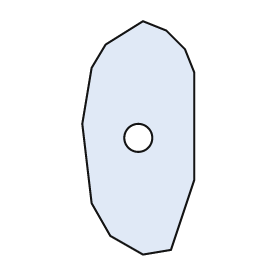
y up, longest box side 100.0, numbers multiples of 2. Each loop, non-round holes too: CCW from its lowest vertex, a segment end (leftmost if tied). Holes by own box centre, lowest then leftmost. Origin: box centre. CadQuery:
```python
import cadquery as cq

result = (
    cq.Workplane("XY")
    .moveTo(2.0, -50.0)
    .lineTo(14.0, -48.0)
    .lineTo(24.0, -18.0)
    .lineTo(24.0, 28.0)
    .lineTo(20.0, 38.0)
    .lineTo(12.0, 46.0)
    .lineTo(2.0, 50.0)
    .lineTo(-14.0, 40.0)
    .lineTo(-20.0, 30.0)
    .lineTo(-24.0, 6.0)
    .lineTo(-20.0, -28.0)
    .lineTo(-12.0, -42.0)
    .close()
    .moveTo(0.0, 0.0)
    .circle(6.0)
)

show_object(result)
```